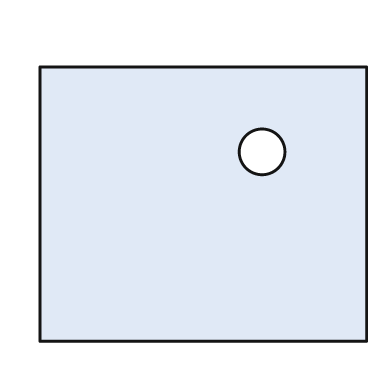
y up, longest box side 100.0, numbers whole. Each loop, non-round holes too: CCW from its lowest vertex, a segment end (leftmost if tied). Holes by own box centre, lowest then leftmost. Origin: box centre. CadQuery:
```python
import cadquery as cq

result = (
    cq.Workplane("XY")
    .moveTo(-50.0, -42.0)
    .lineTo(50.0, -42.0)
    .lineTo(50.0, 42.0)
    .lineTo(-50.0, 42.0)
    .close()
    .moveTo(18.0, 16.0)
    .circle(7.0)
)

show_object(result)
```